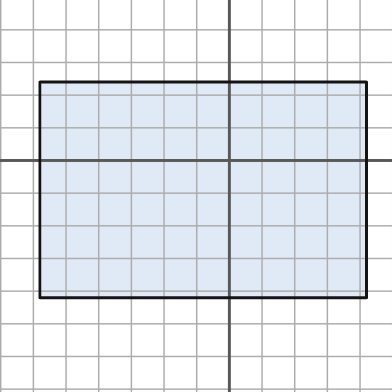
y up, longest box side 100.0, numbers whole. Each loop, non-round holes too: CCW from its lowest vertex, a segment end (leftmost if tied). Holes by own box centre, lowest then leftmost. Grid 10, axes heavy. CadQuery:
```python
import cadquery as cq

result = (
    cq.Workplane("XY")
    .moveTo(-58.0, -42.0)
    .lineTo(42.0, -42.0)
    .lineTo(42.0, 24.0)
    .lineTo(-58.0, 24.0)
    .close()
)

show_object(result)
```